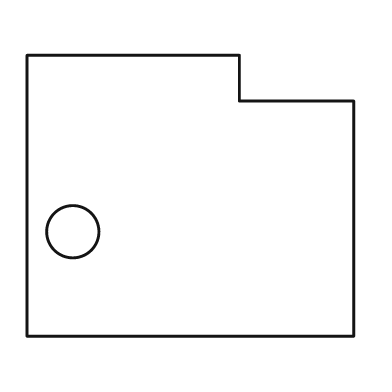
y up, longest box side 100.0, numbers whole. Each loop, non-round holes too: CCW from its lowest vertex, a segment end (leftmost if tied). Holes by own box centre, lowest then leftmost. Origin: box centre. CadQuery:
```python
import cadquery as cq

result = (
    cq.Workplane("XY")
    .moveTo(-50.0, -43.0)
    .lineTo(50.0, -43.0)
    .lineTo(50.0, 29.0)
    .lineTo(15.0, 29.0)
    .lineTo(15.0, 43.0)
    .lineTo(-50.0, 43.0)
    .close()
    .moveTo(-36.0, -11.0)
    .circle(8.0)
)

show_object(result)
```